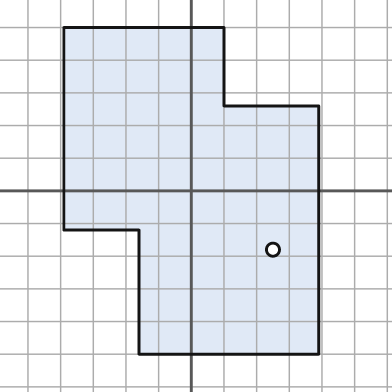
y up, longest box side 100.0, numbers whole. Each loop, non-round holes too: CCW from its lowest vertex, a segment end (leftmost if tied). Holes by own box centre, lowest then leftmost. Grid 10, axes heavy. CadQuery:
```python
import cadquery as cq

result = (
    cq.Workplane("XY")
    .moveTo(-16.0, -50.0)
    .lineTo(39.0, -50.0)
    .lineTo(39.0, 26.0)
    .lineTo(10.0, 26.0)
    .lineTo(10.0, 50.0)
    .lineTo(-39.0, 50.0)
    .lineTo(-39.0, -12.0)
    .lineTo(-16.0, -12.0)
    .close()
    .moveTo(25.0, -18.0)
    .circle(2.0)
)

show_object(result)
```